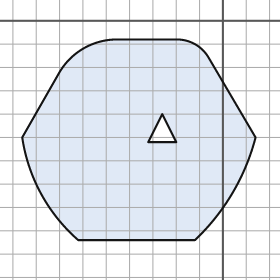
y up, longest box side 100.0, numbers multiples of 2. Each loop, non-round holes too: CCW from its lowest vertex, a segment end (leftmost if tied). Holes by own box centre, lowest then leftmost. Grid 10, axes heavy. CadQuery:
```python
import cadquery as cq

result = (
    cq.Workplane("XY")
    .moveTo(-62.0, -94.0)
    .lineTo(-12.0, -94.0)
    .threePointArc((4.0, -74.0), (14.0, -50.0))
    .lineTo(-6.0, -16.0)
    .threePointArc((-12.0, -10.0), (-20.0, -8.0))
    .lineTo(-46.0, -8.0)
    .threePointArc((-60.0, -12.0), (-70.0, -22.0))
    .lineTo(-86.0, -50.0)
    .threePointArc((-78.0, -74.0), (-62.0, -94.0))
    .close()
    .moveTo(-32.0, -52.0)
    .lineTo(-20.0, -52.0)
    .lineTo(-26.0, -40.0)
    .close()
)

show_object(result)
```